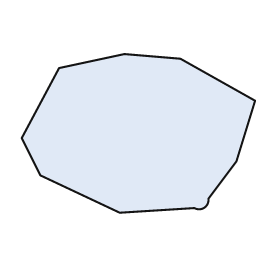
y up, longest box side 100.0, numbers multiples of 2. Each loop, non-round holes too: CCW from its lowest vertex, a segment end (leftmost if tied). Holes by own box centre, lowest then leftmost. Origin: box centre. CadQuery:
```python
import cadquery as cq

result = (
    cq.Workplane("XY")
    .moveTo(-8.0, -34.0)
    .lineTo(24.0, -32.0)
    .threePointArc((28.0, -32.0), (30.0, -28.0))
    .lineTo(42.0, -12.0)
    .lineTo(50.0, 14.0)
    .lineTo(18.0, 32.0)
    .lineTo(-6.0, 34.0)
    .lineTo(-34.0, 28.0)
    .lineTo(-50.0, -2.0)
    .lineTo(-42.0, -18.0)
    .close()
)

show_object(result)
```